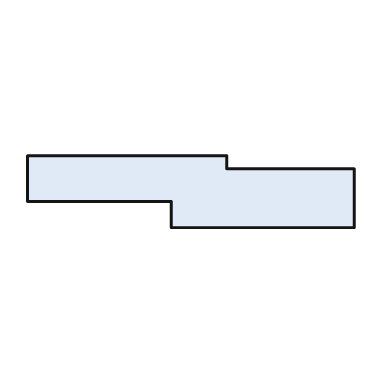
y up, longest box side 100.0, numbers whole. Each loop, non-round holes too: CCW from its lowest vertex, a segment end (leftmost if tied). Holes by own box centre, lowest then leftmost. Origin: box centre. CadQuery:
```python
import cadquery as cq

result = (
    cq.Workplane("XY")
    .moveTo(-6.0, -11.0)
    .lineTo(50.0, -11.0)
    .lineTo(50.0, 7.0)
    .lineTo(11.0, 7.0)
    .lineTo(11.0, 11.0)
    .lineTo(-50.0, 11.0)
    .lineTo(-50.0, -3.0)
    .lineTo(-6.0, -3.0)
    .close()
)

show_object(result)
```